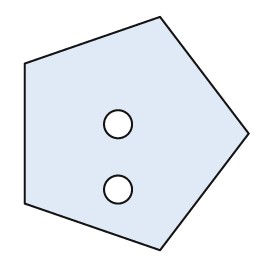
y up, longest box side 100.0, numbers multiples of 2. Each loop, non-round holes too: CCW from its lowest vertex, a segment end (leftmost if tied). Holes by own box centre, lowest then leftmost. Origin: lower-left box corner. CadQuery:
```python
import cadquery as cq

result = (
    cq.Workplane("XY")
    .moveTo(58.0, 0.0)
    .lineTo(96.0, 50.0)
    .lineTo(58.0, 100.0)
    .lineTo(0.0, 80.0)
    .lineTo(0.0, 20.0)
    .close()
    .moveTo(40.0, 26.0)
    .circle(6.0)
    .moveTo(40.0, 54.0)
    .circle(6.0)
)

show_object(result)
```